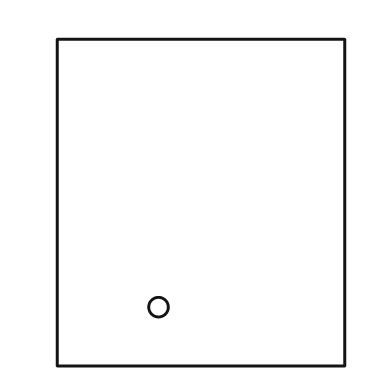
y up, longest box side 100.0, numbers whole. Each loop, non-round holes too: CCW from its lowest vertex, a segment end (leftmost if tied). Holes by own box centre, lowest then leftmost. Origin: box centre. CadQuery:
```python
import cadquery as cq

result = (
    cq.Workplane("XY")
    .moveTo(-44.0, -50.0)
    .lineTo(44.0, -50.0)
    .lineTo(44.0, 50.0)
    .lineTo(-44.0, 50.0)
    .close()
    .moveTo(-13.0, -32.0)
    .circle(3.0)
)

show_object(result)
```